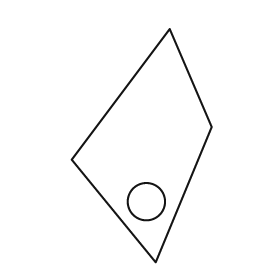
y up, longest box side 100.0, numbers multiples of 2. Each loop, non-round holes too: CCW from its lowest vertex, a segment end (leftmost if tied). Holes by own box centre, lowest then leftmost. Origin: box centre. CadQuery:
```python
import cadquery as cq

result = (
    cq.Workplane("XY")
    .moveTo(6.0, -50.0)
    .lineTo(30.0, 8.0)
    .lineTo(12.0, 50.0)
    .lineTo(-30.0, -6.0)
    .close()
    .moveTo(2.0, -24.0)
    .circle(8.0)
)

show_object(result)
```